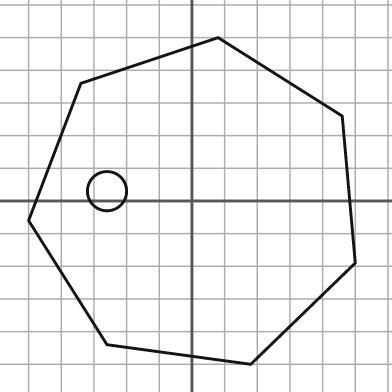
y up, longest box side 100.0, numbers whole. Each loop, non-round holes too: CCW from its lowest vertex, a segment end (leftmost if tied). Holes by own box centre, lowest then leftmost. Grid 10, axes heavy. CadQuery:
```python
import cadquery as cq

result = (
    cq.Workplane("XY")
    .moveTo(18.0, -50.0)
    .lineTo(50.0, -19.0)
    .lineTo(46.0, 26.0)
    .lineTo(8.0, 50.0)
    .lineTo(-34.0, 36.0)
    .lineTo(-50.0, -6.0)
    .lineTo(-26.0, -44.0)
    .close()
    .moveTo(-26.0, 3.0)
    .circle(6.0)
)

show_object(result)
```